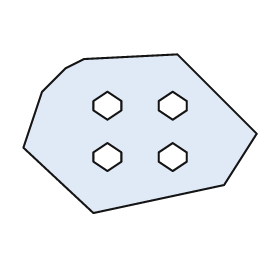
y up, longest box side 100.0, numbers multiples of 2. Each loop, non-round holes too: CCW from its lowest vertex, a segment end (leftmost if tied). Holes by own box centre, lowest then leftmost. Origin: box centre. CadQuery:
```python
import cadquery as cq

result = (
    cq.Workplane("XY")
    .moveTo(-20.0, -34.0)
    .lineTo(36.0, -22.0)
    .lineTo(50.0, 0.0)
    .lineTo(16.0, 34.0)
    .lineTo(-24.0, 32.0)
    .lineTo(-32.0, 28.0)
    .lineTo(-42.0, 18.0)
    .lineTo(-50.0, -6.0)
    .close()
    .moveTo(-14.0, -16.0)
    .lineTo(-8.0, -12.0)
    .lineTo(-8.0, -8.0)
    .lineTo(-14.0, -4.0)
    .lineTo(-20.0, -8.0)
    .lineTo(-20.0, -12.0)
    .close()
    .moveTo(14.0, -16.0)
    .lineTo(20.0, -12.0)
    .lineTo(20.0, -8.0)
    .lineTo(14.0, -4.0)
    .lineTo(8.0, -8.0)
    .lineTo(8.0, -12.0)
    .close()
    .moveTo(-14.0, 6.0)
    .lineTo(-8.0, 10.0)
    .lineTo(-8.0, 14.0)
    .lineTo(-14.0, 18.0)
    .lineTo(-20.0, 14.0)
    .lineTo(-20.0, 10.0)
    .close()
    .moveTo(14.0, 6.0)
    .lineTo(20.0, 10.0)
    .lineTo(20.0, 14.0)
    .lineTo(14.0, 18.0)
    .lineTo(8.0, 14.0)
    .lineTo(8.0, 10.0)
    .close()
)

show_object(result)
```